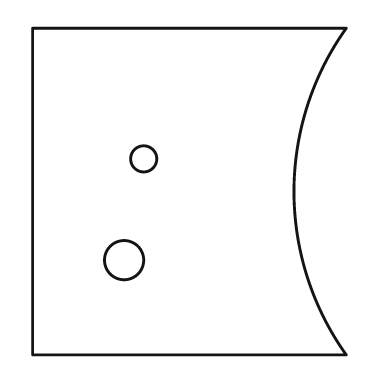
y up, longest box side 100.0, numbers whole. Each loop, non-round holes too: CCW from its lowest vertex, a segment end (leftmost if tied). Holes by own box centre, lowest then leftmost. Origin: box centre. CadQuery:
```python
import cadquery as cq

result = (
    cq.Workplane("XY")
    .moveTo(-48.0, -50.0)
    .lineTo(48.0, -50.0)
    .threePointArc((32.0, 0.0), (48.0, 50.0))
    .lineTo(-48.0, 50.0)
    .close()
    .moveTo(-20.0, -21.0)
    .circle(6.0)
    .moveTo(-14.0, 10.0)
    .circle(4.0)
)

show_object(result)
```